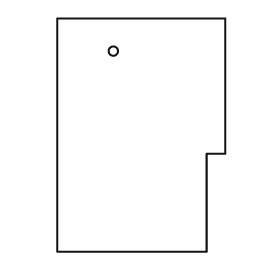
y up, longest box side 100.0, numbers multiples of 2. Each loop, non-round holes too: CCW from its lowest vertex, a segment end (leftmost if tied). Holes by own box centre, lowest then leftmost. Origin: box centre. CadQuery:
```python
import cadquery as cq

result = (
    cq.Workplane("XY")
    .moveTo(-36.0, -50.0)
    .lineTo(28.0, -50.0)
    .lineTo(28.0, -8.0)
    .lineTo(36.0, -8.0)
    .lineTo(36.0, 50.0)
    .lineTo(-36.0, 50.0)
    .close()
    .moveTo(-12.0, 36.0)
    .circle(2.0)
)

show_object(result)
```